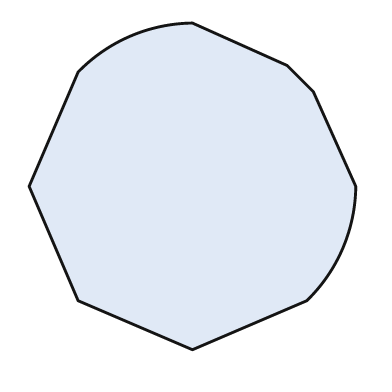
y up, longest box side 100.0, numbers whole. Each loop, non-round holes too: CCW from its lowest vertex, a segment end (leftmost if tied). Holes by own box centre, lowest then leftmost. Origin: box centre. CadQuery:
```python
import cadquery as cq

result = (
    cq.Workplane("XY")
    .moveTo(0.0, -50.0)
    .lineTo(35.0, -35.0)
    .threePointArc((46.0, -19.0), (50.0, 0.0))
    .lineTo(37.0, 29.0)
    .lineTo(29.0, 37.0)
    .lineTo(0.0, 50.0)
    .threePointArc((-19.0, 46.0), (-35.0, 35.0))
    .lineTo(-50.0, 0.0)
    .lineTo(-35.0, -35.0)
    .close()
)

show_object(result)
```